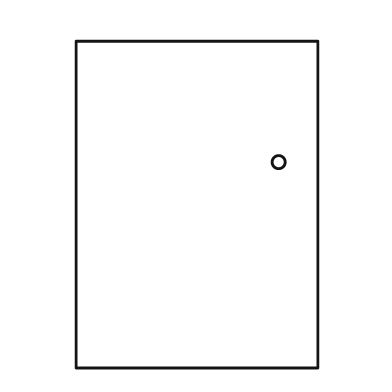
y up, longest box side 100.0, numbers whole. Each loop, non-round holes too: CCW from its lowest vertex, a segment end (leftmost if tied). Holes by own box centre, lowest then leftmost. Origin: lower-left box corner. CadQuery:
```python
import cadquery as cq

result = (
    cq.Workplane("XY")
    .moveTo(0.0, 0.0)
    .lineTo(74.0, 0.0)
    .lineTo(74.0, 100.0)
    .lineTo(0.0, 100.0)
    .close()
    .moveTo(62.0, 63.0)
    .circle(2.0)
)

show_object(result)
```